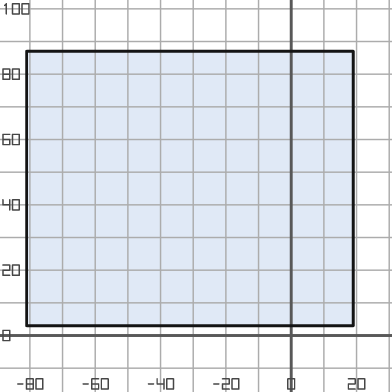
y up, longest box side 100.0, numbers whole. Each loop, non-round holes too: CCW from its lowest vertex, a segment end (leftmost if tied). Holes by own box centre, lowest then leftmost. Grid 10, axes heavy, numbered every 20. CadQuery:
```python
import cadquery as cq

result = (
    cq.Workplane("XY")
    .moveTo(-81.0, 3.0)
    .lineTo(19.0, 3.0)
    .lineTo(19.0, 87.0)
    .lineTo(-81.0, 87.0)
    .close()
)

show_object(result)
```